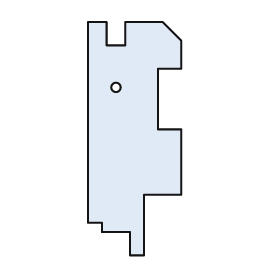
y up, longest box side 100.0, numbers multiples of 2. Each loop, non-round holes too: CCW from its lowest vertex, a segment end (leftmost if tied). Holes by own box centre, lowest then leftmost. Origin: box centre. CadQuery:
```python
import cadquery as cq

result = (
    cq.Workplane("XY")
    .moveTo(-2.0, -50.0)
    .lineTo(4.0, -50.0)
    .lineTo(4.0, -24.0)
    .lineTo(20.0, -24.0)
    .lineTo(20.0, 4.0)
    .lineTo(10.0, 4.0)
    .lineTo(10.0, 30.0)
    .lineTo(20.0, 30.0)
    .lineTo(20.0, 42.0)
    .lineTo(12.0, 50.0)
    .lineTo(-4.0, 50.0)
    .lineTo(-4.0, 40.0)
    .lineTo(-12.0, 40.0)
    .lineTo(-12.0, 50.0)
    .lineTo(-20.0, 50.0)
    .lineTo(-20.0, -36.0)
    .lineTo(-14.0, -36.0)
    .lineTo(-14.0, -40.0)
    .lineTo(-2.0, -40.0)
    .close()
    .moveTo(-8.0, 22.0)
    .circle(2.0)
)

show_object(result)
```